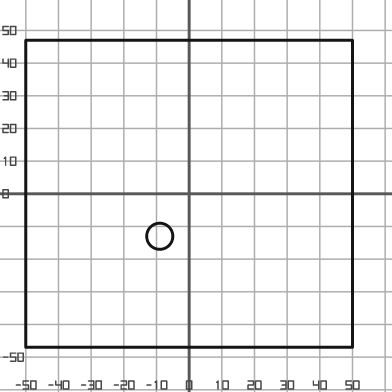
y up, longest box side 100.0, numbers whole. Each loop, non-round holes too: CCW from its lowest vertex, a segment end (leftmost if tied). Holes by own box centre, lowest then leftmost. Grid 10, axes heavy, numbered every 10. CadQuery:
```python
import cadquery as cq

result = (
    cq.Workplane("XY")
    .moveTo(-50.0, -47.0)
    .lineTo(50.0, -47.0)
    .lineTo(50.0, 47.0)
    .lineTo(-50.0, 47.0)
    .close()
    .moveTo(-9.0, -13.0)
    .circle(4.0)
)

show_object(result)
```